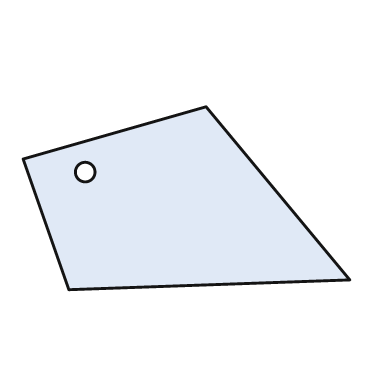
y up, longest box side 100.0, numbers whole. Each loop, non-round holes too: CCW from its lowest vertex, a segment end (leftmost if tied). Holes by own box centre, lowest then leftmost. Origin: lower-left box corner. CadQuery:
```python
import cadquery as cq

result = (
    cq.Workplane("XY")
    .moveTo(14.0, 0.0)
    .lineTo(100.0, 3.0)
    .lineTo(56.0, 56.0)
    .lineTo(0.0, 40.0)
    .close()
    .moveTo(19.0, 36.0)
    .circle(3.0)
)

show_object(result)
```